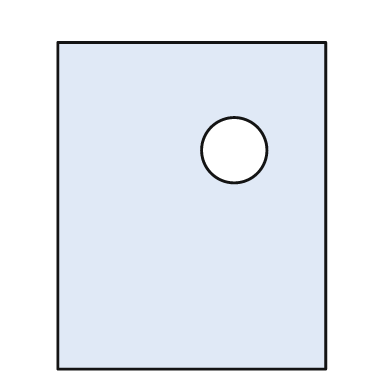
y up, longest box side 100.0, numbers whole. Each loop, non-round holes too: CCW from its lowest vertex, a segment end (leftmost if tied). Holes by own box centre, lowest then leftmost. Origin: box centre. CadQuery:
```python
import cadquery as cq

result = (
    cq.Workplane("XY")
    .moveTo(-41.0, -50.0)
    .lineTo(41.0, -50.0)
    .lineTo(41.0, 50.0)
    .lineTo(-41.0, 50.0)
    .close()
    .moveTo(13.0, 17.0)
    .circle(10.0)
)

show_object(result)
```